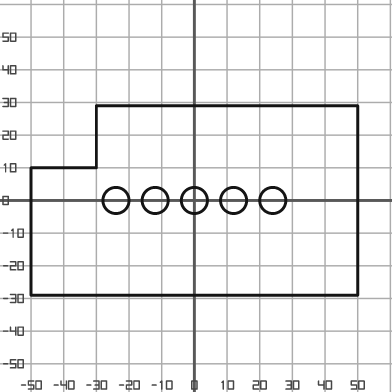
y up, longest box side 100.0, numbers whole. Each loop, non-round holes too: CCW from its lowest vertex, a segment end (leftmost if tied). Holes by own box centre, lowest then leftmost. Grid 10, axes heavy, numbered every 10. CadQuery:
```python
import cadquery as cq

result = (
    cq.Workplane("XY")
    .moveTo(-50.0, -29.0)
    .lineTo(50.0, -29.0)
    .lineTo(50.0, 29.0)
    .lineTo(-30.0, 29.0)
    .lineTo(-30.0, 10.0)
    .lineTo(-50.0, 10.0)
    .close()
    .moveTo(-24.0, 0.0)
    .circle(4.0)
    .moveTo(-12.0, 0.0)
    .circle(4.0)
    .moveTo(0.0, 0.0)
    .circle(4.0)
    .moveTo(12.0, 0.0)
    .circle(4.0)
    .moveTo(24.0, 0.0)
    .circle(4.0)
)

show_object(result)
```